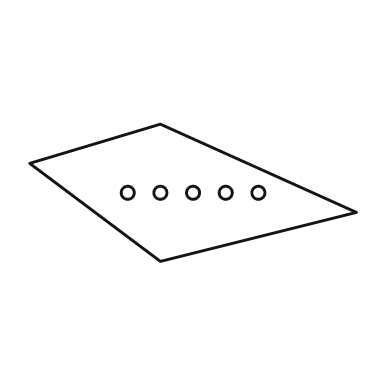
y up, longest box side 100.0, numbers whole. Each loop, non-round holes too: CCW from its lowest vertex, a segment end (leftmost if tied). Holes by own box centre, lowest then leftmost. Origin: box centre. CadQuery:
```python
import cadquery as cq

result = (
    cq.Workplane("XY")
    .moveTo(-10.0, -21.0)
    .lineTo(50.0, -6.0)
    .lineTo(-10.0, 21.0)
    .lineTo(-50.0, 9.0)
    .close()
    .moveTo(-20.0, 0.0)
    .circle(2.0)
    .moveTo(-10.0, 0.0)
    .circle(2.0)
    .moveTo(0.0, 0.0)
    .circle(2.0)
    .moveTo(10.0, 0.0)
    .circle(2.0)
    .moveTo(20.0, 0.0)
    .circle(2.0)
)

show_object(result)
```